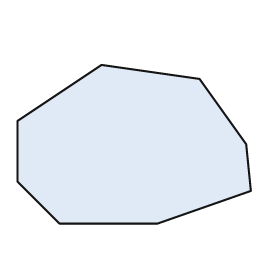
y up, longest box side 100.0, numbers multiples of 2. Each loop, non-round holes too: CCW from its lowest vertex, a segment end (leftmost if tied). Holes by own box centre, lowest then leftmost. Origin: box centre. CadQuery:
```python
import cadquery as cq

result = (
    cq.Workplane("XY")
    .moveTo(-32.0, -34.0)
    .lineTo(10.0, -34.0)
    .lineTo(50.0, -20.0)
    .lineTo(48.0, 0.0)
    .lineTo(28.0, 28.0)
    .lineTo(-14.0, 34.0)
    .lineTo(-50.0, 10.0)
    .lineTo(-50.0, -16.0)
    .close()
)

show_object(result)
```